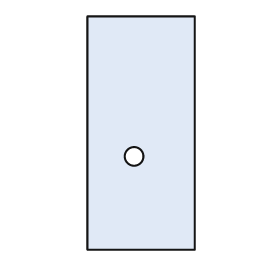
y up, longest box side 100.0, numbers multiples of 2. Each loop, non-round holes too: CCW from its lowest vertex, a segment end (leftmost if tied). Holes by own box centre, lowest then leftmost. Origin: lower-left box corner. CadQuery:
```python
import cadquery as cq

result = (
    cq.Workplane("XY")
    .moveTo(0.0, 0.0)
    .lineTo(46.0, 0.0)
    .lineTo(46.0, 100.0)
    .lineTo(0.0, 100.0)
    .close()
    .moveTo(20.0, 40.0)
    .circle(4.0)
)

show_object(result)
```